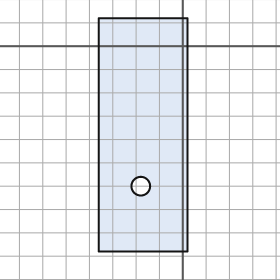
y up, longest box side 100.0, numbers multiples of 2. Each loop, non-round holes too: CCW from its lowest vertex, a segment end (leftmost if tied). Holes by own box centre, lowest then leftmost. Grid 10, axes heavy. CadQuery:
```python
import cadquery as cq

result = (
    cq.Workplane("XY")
    .moveTo(-36.0, -88.0)
    .lineTo(2.0, -88.0)
    .lineTo(2.0, 12.0)
    .lineTo(-36.0, 12.0)
    .close()
    .moveTo(-18.0, -60.0)
    .circle(4.0)
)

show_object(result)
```